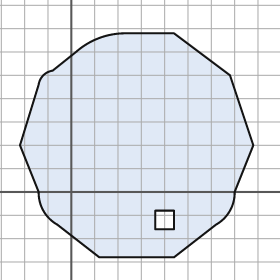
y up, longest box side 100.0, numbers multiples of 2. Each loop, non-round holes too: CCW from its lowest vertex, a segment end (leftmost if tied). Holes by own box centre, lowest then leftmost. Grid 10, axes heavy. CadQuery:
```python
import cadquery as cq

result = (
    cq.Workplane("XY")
    .moveTo(12.0, -28.0)
    .lineTo(44.0, -28.0)
    .lineTo(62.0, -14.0)
    .threePointArc((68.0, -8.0), (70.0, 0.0))
    .lineTo(78.0, 20.0)
    .lineTo(68.0, 50.0)
    .lineTo(44.0, 68.0)
    .lineTo(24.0, 68.0)
    .threePointArc((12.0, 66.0), (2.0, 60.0))
    .lineTo(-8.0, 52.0)
    .threePointArc((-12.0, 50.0), (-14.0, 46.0))
    .lineTo(-22.0, 20.0)
    .lineTo(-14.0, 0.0)
    .threePointArc((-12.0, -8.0), (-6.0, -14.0))
    .close()
    .moveTo(36.0, -16.0)
    .lineTo(44.0, -16.0)
    .lineTo(44.0, -8.0)
    .lineTo(36.0, -8.0)
    .close()
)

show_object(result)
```